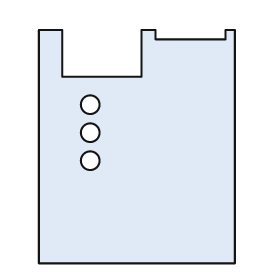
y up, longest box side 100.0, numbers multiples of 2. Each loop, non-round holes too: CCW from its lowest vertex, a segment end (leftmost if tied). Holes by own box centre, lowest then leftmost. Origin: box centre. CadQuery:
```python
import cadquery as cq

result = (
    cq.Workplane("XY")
    .moveTo(-42.0, -50.0)
    .lineTo(42.0, -50.0)
    .lineTo(42.0, 50.0)
    .lineTo(38.0, 50.0)
    .lineTo(38.0, 46.0)
    .lineTo(8.0, 46.0)
    .lineTo(8.0, 50.0)
    .lineTo(2.0, 50.0)
    .lineTo(2.0, 30.0)
    .lineTo(-32.0, 30.0)
    .lineTo(-32.0, 50.0)
    .lineTo(-42.0, 50.0)
    .close()
    .moveTo(-20.0, -6.0)
    .circle(4.0)
    .moveTo(-20.0, 6.0)
    .circle(4.0)
    .moveTo(-20.0, 18.0)
    .circle(4.0)
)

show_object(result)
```